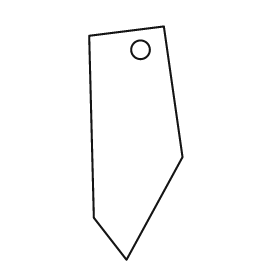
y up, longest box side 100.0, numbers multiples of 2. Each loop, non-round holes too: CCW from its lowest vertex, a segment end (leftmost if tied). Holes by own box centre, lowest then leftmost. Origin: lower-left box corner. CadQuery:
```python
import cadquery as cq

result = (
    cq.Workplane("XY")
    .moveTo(16.0, 0.0)
    .lineTo(40.0, 44.0)
    .lineTo(32.0, 100.0)
    .lineTo(0.0, 96.0)
    .lineTo(2.0, 18.0)
    .close()
    .moveTo(22.0, 90.0)
    .circle(4.0)
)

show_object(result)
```